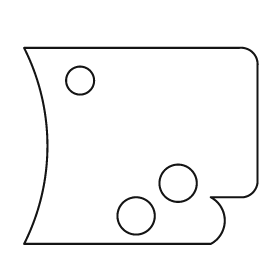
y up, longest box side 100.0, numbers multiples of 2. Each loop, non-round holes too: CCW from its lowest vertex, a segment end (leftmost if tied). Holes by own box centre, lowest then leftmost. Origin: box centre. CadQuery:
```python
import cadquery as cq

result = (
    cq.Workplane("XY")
    .moveTo(-50.0, -42.0)
    .lineTo(30.0, -42.0)
    .threePointArc((36.0, -32.0), (30.0, -22.0))
    .lineTo(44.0, -22.0)
    .threePointArc((48.0, -20.0), (50.0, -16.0))
    .lineTo(50.0, 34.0)
    .threePointArc((48.0, 40.0), (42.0, 42.0))
    .lineTo(-50.0, 42.0)
    .threePointArc((-40.0, 0.0), (-50.0, -42.0))
    .close()
    .moveTo(-2.0, -30.0)
    .circle(8.0)
    .moveTo(16.0, -16.0)
    .circle(8.0)
    .moveTo(-26.0, 28.0)
    .circle(6.0)
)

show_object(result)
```